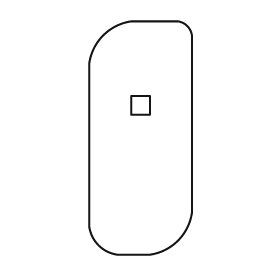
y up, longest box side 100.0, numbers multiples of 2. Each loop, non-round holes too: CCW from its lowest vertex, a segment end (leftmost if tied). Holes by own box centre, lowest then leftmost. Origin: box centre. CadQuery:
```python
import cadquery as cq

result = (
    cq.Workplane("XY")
    .moveTo(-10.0, -50.0)
    .lineTo(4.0, -50.0)
    .threePointArc((16.0, -44.0), (22.0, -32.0))
    .lineTo(22.0, 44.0)
    .threePointArc((20.0, 48.0), (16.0, 50.0))
    .lineTo(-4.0, 50.0)
    .threePointArc((-16.0, 44.0), (-22.0, 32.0))
    .lineTo(-22.0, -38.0)
    .threePointArc((-18.0, -46.0), (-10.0, -50.0))
    .close()
    .moveTo(-4.0, 10.0)
    .lineTo(4.0, 10.0)
    .lineTo(4.0, 18.0)
    .lineTo(-4.0, 18.0)
    .close()
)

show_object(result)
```